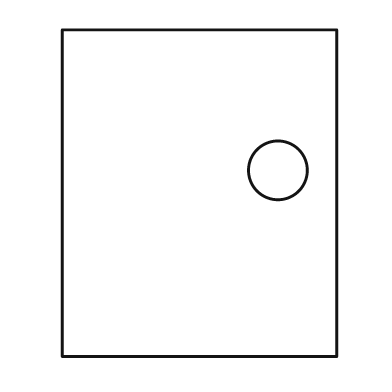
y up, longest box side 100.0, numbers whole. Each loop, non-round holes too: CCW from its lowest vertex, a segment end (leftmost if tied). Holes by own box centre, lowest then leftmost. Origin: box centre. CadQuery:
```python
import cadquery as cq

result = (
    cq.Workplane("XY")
    .moveTo(-42.0, -50.0)
    .lineTo(42.0, -50.0)
    .lineTo(42.0, 50.0)
    .lineTo(-42.0, 50.0)
    .close()
    .moveTo(24.0, 7.0)
    .circle(9.0)
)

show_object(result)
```